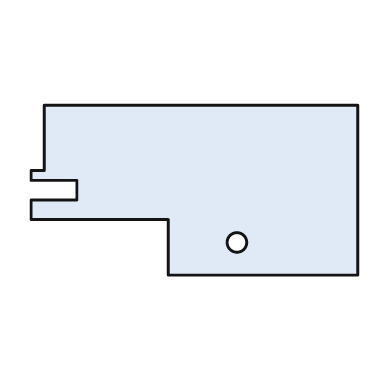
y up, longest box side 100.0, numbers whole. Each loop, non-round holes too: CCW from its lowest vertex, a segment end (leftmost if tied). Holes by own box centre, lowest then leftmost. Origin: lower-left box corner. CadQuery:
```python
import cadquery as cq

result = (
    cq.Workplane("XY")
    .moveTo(42.0, 0.0)
    .lineTo(100.0, 0.0)
    .lineTo(100.0, 52.0)
    .lineTo(4.0, 52.0)
    .lineTo(4.0, 32.0)
    .lineTo(0.0, 32.0)
    .lineTo(0.0, 29.0)
    .lineTo(14.0, 29.0)
    .lineTo(14.0, 23.0)
    .lineTo(0.0, 23.0)
    .lineTo(0.0, 17.0)
    .lineTo(42.0, 17.0)
    .close()
    .moveTo(63.0, 10.0)
    .circle(3.0)
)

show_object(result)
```